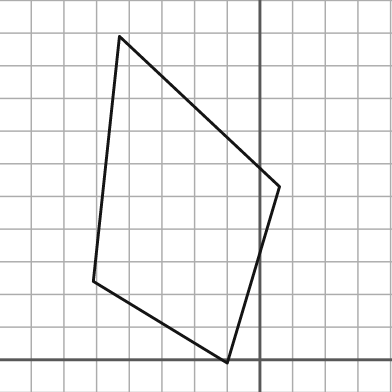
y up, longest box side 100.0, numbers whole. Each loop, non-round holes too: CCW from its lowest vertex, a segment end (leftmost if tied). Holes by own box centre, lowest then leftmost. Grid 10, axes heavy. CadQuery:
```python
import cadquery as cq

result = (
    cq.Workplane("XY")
    .moveTo(-10.0, -1.0)
    .lineTo(6.0, 53.0)
    .lineTo(-43.0, 99.0)
    .lineTo(-51.0, 24.0)
    .close()
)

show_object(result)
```